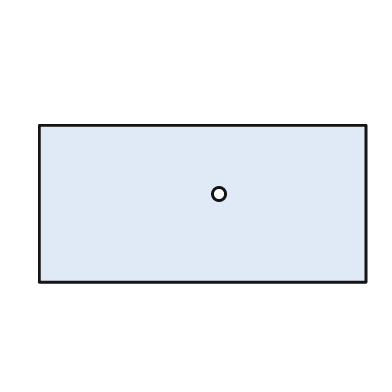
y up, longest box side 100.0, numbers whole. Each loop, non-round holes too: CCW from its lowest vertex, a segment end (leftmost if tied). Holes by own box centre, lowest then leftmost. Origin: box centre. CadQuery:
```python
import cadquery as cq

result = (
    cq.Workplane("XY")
    .moveTo(-50.0, -24.0)
    .lineTo(50.0, -24.0)
    .lineTo(50.0, 24.0)
    .lineTo(-50.0, 24.0)
    .close()
    .moveTo(5.0, 3.0)
    .circle(2.0)
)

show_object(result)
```